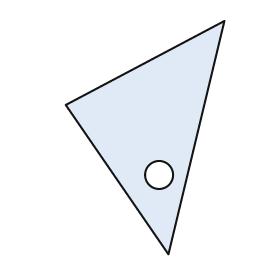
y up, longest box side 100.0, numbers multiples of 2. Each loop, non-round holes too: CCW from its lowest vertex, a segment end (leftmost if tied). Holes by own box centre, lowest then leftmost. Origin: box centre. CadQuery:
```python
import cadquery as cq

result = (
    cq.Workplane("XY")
    .moveTo(10.0, -50.0)
    .lineTo(34.0, 50.0)
    .lineTo(-34.0, 14.0)
    .close()
    .moveTo(6.0, -16.0)
    .circle(6.0)
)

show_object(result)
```